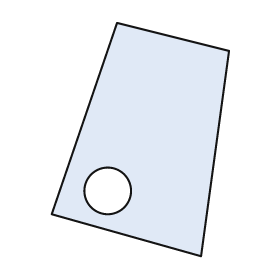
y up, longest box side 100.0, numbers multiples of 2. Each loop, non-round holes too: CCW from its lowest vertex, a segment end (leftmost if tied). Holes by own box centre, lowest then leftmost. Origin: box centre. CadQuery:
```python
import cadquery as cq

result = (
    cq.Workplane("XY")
    .moveTo(26.0, -50.0)
    .lineTo(38.0, 38.0)
    .lineTo(-10.0, 50.0)
    .lineTo(-38.0, -32.0)
    .close()
    .moveTo(-14.0, -22.0)
    .circle(10.0)
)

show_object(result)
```